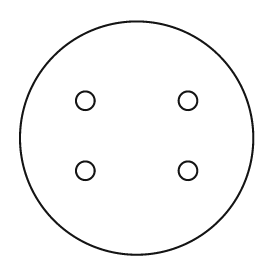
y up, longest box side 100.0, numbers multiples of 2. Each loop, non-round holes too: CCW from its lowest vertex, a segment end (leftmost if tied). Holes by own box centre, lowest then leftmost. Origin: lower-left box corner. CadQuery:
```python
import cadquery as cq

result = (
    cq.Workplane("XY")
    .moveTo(50.0, 50.0)
    .circle(50.0)
    .moveTo(28.0, 36.0)
    .circle(4.0)
    .moveTo(72.0, 36.0)
    .circle(4.0)
    .moveTo(28.0, 66.0)
    .circle(4.0)
    .moveTo(72.0, 66.0)
    .circle(4.0)
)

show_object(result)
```